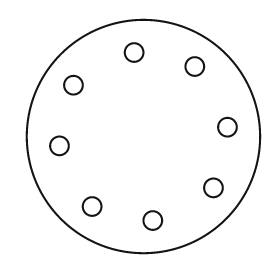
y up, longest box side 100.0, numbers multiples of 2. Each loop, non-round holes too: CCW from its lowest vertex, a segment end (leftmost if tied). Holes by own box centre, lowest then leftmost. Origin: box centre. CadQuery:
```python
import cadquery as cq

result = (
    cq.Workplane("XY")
    .moveTo(0.0, 0.0)
    .circle(50.0)
    .moveTo(4.0, -36.0)
    .circle(4.0)
    .moveTo(-22.0, -30.0)
    .circle(4.0)
    .moveTo(30.0, -22.0)
    .circle(4.0)
    .moveTo(-36.0, -4.0)
    .circle(4.0)
    .moveTo(36.0, 4.0)
    .circle(4.0)
    .moveTo(-30.0, 22.0)
    .circle(4.0)
    .moveTo(22.0, 30.0)
    .circle(4.0)
    .moveTo(-4.0, 36.0)
    .circle(4.0)
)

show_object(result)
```